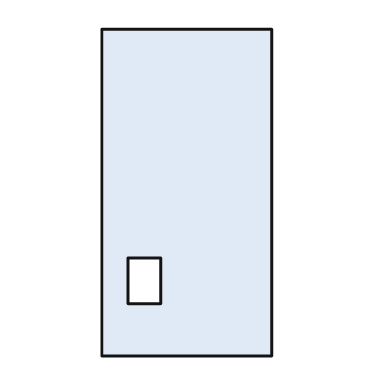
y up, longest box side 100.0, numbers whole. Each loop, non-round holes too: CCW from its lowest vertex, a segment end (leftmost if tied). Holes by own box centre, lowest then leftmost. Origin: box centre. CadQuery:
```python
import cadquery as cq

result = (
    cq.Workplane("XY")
    .moveTo(-26.0, -50.0)
    .lineTo(26.0, -50.0)
    .lineTo(26.0, 50.0)
    .lineTo(-26.0, 50.0)
    .close()
    .moveTo(-18.0, -34.0)
    .lineTo(-8.0, -34.0)
    .lineTo(-8.0, -20.0)
    .lineTo(-18.0, -20.0)
    .close()
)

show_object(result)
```